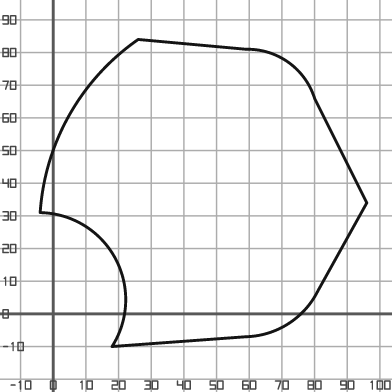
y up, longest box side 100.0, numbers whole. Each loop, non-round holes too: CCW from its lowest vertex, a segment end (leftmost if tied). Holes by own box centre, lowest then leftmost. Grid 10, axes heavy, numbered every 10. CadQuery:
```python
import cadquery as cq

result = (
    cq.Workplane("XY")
    .moveTo(18.0, -10.0)
    .lineTo(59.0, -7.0)
    .threePointArc((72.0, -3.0), (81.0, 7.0))
    .lineTo(96.0, 34.0)
    .lineTo(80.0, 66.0)
    .threePointArc((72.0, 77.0), (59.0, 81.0))
    .lineTo(26.0, 84.0)
    .threePointArc((5.0, 61.0), (-4.0, 31.0))
    .threePointArc((19.0, 17.0), (18.0, -10.0))
    .close()
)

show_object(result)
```